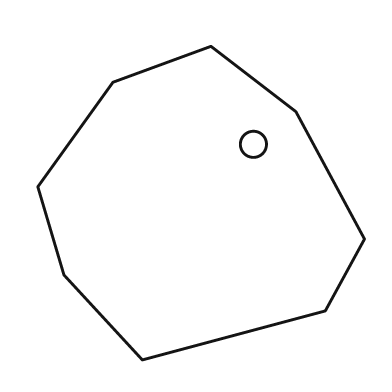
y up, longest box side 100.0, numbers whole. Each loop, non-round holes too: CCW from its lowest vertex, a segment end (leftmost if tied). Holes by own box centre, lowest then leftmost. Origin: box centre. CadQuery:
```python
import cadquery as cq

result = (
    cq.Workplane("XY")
    .moveTo(-18.0, -48.0)
    .lineTo(38.0, -33.0)
    .lineTo(50.0, -11.0)
    .lineTo(29.0, 28.0)
    .lineTo(3.0, 48.0)
    .lineTo(-27.0, 37.0)
    .lineTo(-50.0, 5.0)
    .lineTo(-42.0, -22.0)
    .close()
    .moveTo(16.0, 18.0)
    .circle(4.0)
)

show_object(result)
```